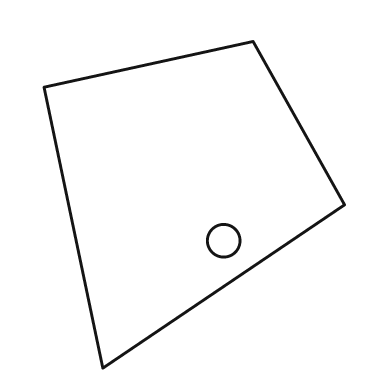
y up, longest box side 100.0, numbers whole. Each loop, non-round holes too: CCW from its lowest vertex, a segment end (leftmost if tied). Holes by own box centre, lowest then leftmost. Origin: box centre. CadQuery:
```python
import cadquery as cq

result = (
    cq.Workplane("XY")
    .moveTo(-28.0, -50.0)
    .lineTo(46.0, 0.0)
    .lineTo(18.0, 50.0)
    .lineTo(-46.0, 36.0)
    .close()
    .moveTo(9.0, -11.0)
    .circle(5.0)
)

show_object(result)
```